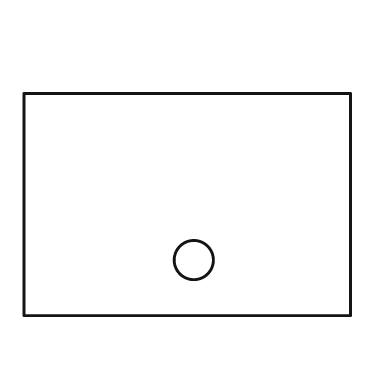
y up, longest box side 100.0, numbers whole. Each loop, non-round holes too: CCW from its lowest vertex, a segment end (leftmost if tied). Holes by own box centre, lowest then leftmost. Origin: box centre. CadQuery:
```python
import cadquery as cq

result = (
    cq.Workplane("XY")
    .moveTo(-50.0, -34.0)
    .lineTo(50.0, -34.0)
    .lineTo(50.0, 34.0)
    .lineTo(-50.0, 34.0)
    .close()
    .moveTo(2.0, -17.0)
    .circle(6.0)
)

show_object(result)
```